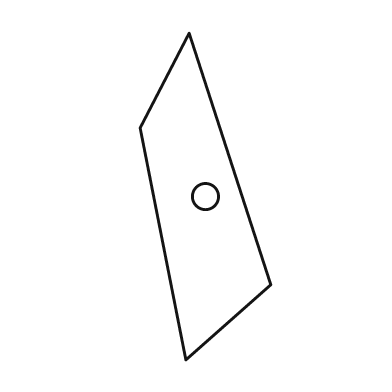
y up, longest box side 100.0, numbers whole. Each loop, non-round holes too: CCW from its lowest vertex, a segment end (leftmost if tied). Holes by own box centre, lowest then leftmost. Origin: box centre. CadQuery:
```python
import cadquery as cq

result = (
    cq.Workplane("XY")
    .moveTo(-6.0, -50.0)
    .lineTo(20.0, -27.0)
    .lineTo(-5.0, 50.0)
    .lineTo(-20.0, 21.0)
    .close()
    .moveTo(0.0, 0.0)
    .circle(4.0)
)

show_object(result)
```